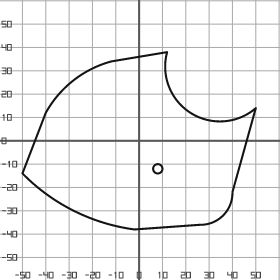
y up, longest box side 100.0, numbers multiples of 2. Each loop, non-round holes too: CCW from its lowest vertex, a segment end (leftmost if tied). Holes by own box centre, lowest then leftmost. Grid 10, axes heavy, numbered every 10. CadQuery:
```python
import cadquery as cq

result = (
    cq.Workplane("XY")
    .moveTo(-2.0, -38.0)
    .lineTo(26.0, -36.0)
    .threePointArc((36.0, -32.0), (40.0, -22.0))
    .lineTo(50.0, 14.0)
    .threePointArc((22.0, 12.0), (12.0, 38.0))
    .lineTo(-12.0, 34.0)
    .threePointArc((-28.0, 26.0), (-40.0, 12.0))
    .lineTo(-50.0, -14.0)
    .threePointArc((-28.0, -30.0), (-2.0, -38.0))
    .close()
    .moveTo(8.0, -12.0)
    .circle(2.0)
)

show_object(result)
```